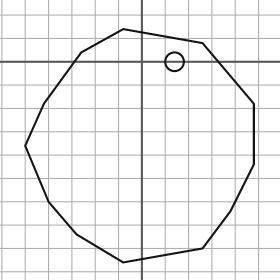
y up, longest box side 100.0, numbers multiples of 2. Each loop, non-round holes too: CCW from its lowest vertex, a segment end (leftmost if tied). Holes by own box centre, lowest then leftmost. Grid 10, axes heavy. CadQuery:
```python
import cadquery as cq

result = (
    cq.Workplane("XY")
    .moveTo(-8.0, -86.0)
    .lineTo(26.0, -80.0)
    .lineTo(38.0, -64.0)
    .lineTo(48.0, -44.0)
    .lineTo(48.0, -18.0)
    .lineTo(26.0, 8.0)
    .lineTo(-8.0, 14.0)
    .lineTo(-26.0, 4.0)
    .lineTo(-42.0, -18.0)
    .lineTo(-50.0, -36.0)
    .lineTo(-40.0, -60.0)
    .lineTo(-28.0, -74.0)
    .close()
    .moveTo(14.0, 0.0)
    .circle(4.0)
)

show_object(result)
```